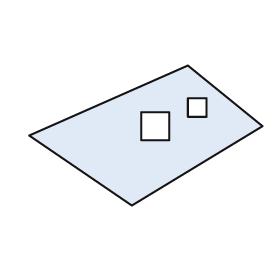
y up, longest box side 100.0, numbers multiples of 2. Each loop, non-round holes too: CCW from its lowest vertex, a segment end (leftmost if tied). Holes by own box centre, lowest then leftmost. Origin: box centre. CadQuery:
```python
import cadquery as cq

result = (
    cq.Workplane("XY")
    .moveTo(-6.0, -30.0)
    .lineTo(50.0, 4.0)
    .lineTo(18.0, 30.0)
    .lineTo(-50.0, 0.0)
    .close()
    .moveTo(-2.0, -2.0)
    .lineTo(10.0, -2.0)
    .lineTo(10.0, 10.0)
    .lineTo(-2.0, 10.0)
    .close()
    .moveTo(18.0, 8.0)
    .lineTo(26.0, 8.0)
    .lineTo(26.0, 16.0)
    .lineTo(18.0, 16.0)
    .close()
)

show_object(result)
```